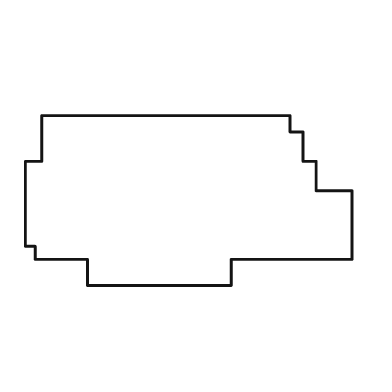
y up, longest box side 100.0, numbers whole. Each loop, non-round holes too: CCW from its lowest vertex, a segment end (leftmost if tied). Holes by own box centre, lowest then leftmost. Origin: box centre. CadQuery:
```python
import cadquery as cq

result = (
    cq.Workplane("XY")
    .moveTo(-31.0, -26.0)
    .lineTo(13.0, -26.0)
    .lineTo(13.0, -18.0)
    .lineTo(50.0, -18.0)
    .lineTo(50.0, 3.0)
    .lineTo(39.0, 3.0)
    .lineTo(39.0, 12.0)
    .lineTo(35.0, 12.0)
    .lineTo(35.0, 21.0)
    .lineTo(31.0, 21.0)
    .lineTo(31.0, 26.0)
    .lineTo(-45.0, 26.0)
    .lineTo(-45.0, 12.0)
    .lineTo(-50.0, 12.0)
    .lineTo(-50.0, -14.0)
    .lineTo(-47.0, -14.0)
    .lineTo(-47.0, -18.0)
    .lineTo(-31.0, -18.0)
    .close()
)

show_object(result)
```